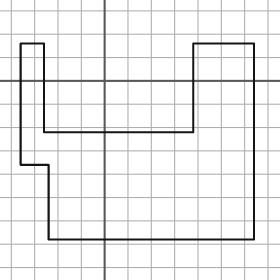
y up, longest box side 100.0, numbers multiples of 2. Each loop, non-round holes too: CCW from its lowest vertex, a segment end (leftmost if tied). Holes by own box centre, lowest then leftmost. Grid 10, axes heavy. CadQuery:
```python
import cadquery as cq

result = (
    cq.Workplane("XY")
    .moveTo(-24.0, -68.0)
    .lineTo(64.0, -68.0)
    .lineTo(64.0, 16.0)
    .lineTo(38.0, 16.0)
    .lineTo(38.0, -22.0)
    .lineTo(-26.0, -22.0)
    .lineTo(-26.0, 16.0)
    .lineTo(-36.0, 16.0)
    .lineTo(-36.0, -36.0)
    .lineTo(-24.0, -36.0)
    .close()
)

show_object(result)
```